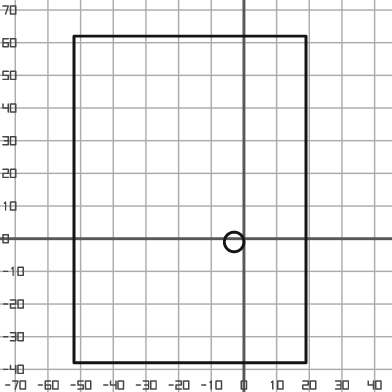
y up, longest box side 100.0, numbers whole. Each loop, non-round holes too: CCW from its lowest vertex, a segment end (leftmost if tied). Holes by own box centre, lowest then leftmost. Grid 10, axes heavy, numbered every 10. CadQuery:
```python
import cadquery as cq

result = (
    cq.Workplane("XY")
    .moveTo(-52.0, -38.0)
    .lineTo(19.0, -38.0)
    .lineTo(19.0, 62.0)
    .lineTo(-52.0, 62.0)
    .close()
    .moveTo(-3.0, -1.0)
    .circle(3.0)
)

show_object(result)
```